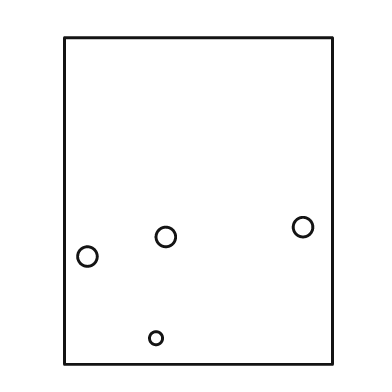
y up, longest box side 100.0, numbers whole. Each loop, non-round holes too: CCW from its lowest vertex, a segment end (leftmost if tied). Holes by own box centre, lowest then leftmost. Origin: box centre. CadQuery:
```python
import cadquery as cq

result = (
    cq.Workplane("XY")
    .moveTo(-41.0, -50.0)
    .lineTo(41.0, -50.0)
    .lineTo(41.0, 50.0)
    .lineTo(-41.0, 50.0)
    .close()
    .moveTo(-13.0, -42.0)
    .circle(2.0)
    .moveTo(-34.0, -17.0)
    .circle(3.0)
    .moveTo(-10.0, -11.0)
    .circle(3.0)
    .moveTo(32.0, -8.0)
    .circle(3.0)
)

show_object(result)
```